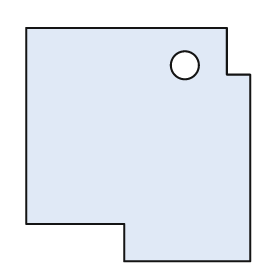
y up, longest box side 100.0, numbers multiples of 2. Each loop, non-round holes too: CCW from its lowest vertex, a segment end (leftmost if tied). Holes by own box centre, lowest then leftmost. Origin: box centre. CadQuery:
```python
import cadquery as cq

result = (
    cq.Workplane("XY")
    .moveTo(-6.0, -50.0)
    .lineTo(48.0, -50.0)
    .lineTo(48.0, 30.0)
    .lineTo(38.0, 30.0)
    .lineTo(38.0, 50.0)
    .lineTo(-48.0, 50.0)
    .lineTo(-48.0, -34.0)
    .lineTo(-6.0, -34.0)
    .close()
    .moveTo(20.0, 34.0)
    .circle(6.0)
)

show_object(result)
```